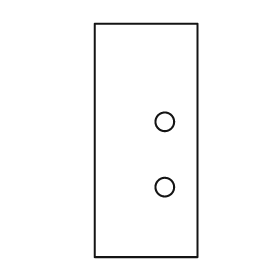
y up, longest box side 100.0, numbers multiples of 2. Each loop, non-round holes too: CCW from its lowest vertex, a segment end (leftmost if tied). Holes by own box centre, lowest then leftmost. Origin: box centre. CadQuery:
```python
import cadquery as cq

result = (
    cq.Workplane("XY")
    .moveTo(-22.0, -50.0)
    .lineTo(22.0, -50.0)
    .lineTo(22.0, 50.0)
    .lineTo(-22.0, 50.0)
    .close()
    .moveTo(8.0, -20.0)
    .circle(4.0)
    .moveTo(8.0, 8.0)
    .circle(4.0)
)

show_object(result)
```